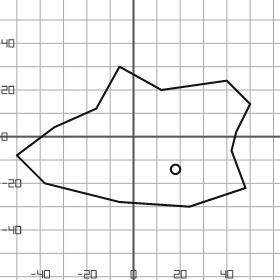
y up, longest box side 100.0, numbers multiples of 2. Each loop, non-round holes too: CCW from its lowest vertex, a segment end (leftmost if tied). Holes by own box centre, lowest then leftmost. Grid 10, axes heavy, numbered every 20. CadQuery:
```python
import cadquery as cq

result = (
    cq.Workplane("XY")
    .moveTo(24.0, -30.0)
    .lineTo(48.0, -22.0)
    .lineTo(42.0, -6.0)
    .lineTo(44.0, 2.0)
    .lineTo(50.0, 14.0)
    .lineTo(40.0, 24.0)
    .lineTo(12.0, 20.0)
    .lineTo(-6.0, 30.0)
    .lineTo(-16.0, 12.0)
    .lineTo(-34.0, 4.0)
    .lineTo(-50.0, -8.0)
    .lineTo(-38.0, -20.0)
    .lineTo(-6.0, -28.0)
    .close()
    .moveTo(18.0, -14.0)
    .circle(2.0)
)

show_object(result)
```